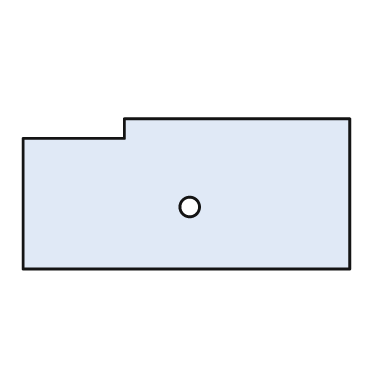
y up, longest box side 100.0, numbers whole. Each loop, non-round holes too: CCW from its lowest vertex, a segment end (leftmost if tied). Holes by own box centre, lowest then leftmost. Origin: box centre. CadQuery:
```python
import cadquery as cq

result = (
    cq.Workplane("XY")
    .moveTo(-50.0, -23.0)
    .lineTo(50.0, -23.0)
    .lineTo(50.0, 23.0)
    .lineTo(-19.0, 23.0)
    .lineTo(-19.0, 17.0)
    .lineTo(-50.0, 17.0)
    .close()
    .moveTo(1.0, -4.0)
    .circle(3.0)
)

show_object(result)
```